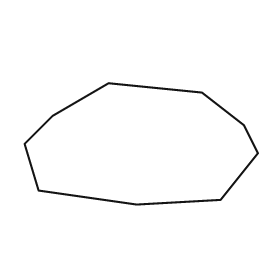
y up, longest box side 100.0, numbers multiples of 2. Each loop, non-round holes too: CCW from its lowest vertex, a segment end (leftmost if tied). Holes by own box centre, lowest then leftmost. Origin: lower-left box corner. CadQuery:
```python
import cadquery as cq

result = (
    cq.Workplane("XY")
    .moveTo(48.0, 0.0)
    .lineTo(84.0, 2.0)
    .lineTo(100.0, 22.0)
    .lineTo(94.0, 34.0)
    .lineTo(76.0, 48.0)
    .lineTo(36.0, 52.0)
    .lineTo(12.0, 38.0)
    .lineTo(0.0, 26.0)
    .lineTo(6.0, 6.0)
    .close()
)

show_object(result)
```